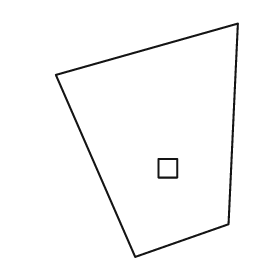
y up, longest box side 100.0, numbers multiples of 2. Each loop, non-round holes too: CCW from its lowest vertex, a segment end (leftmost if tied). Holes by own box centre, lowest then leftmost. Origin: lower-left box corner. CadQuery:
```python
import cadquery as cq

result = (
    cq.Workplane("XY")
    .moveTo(34.0, 0.0)
    .lineTo(74.0, 14.0)
    .lineTo(78.0, 100.0)
    .lineTo(0.0, 78.0)
    .close()
    .moveTo(44.0, 34.0)
    .lineTo(52.0, 34.0)
    .lineTo(52.0, 42.0)
    .lineTo(44.0, 42.0)
    .close()
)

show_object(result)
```